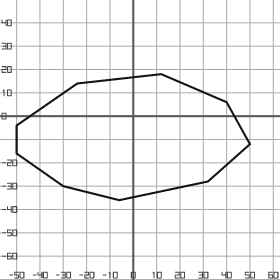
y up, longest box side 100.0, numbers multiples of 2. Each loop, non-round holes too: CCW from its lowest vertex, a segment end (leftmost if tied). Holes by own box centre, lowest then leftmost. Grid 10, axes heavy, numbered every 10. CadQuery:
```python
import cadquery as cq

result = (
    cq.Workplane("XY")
    .moveTo(-6.0, -36.0)
    .lineTo(32.0, -28.0)
    .lineTo(50.0, -12.0)
    .lineTo(40.0, 6.0)
    .lineTo(12.0, 18.0)
    .lineTo(-24.0, 14.0)
    .lineTo(-50.0, -4.0)
    .lineTo(-50.0, -16.0)
    .lineTo(-30.0, -30.0)
    .close()
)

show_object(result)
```